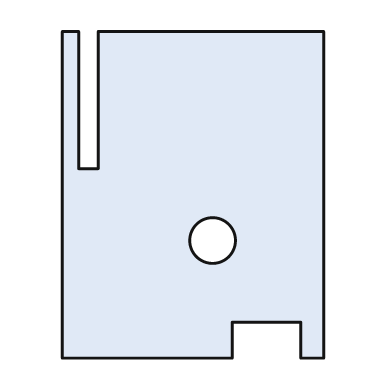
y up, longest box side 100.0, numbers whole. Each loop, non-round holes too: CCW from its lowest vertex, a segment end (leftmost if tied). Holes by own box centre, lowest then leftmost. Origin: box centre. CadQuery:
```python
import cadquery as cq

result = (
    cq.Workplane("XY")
    .moveTo(-40.0, -50.0)
    .lineTo(12.0, -50.0)
    .lineTo(12.0, -39.0)
    .lineTo(33.0, -39.0)
    .lineTo(33.0, -50.0)
    .lineTo(40.0, -50.0)
    .lineTo(40.0, 50.0)
    .lineTo(-29.0, 50.0)
    .lineTo(-29.0, 8.0)
    .lineTo(-35.0, 8.0)
    .lineTo(-35.0, 50.0)
    .lineTo(-40.0, 50.0)
    .close()
    .moveTo(6.0, -14.0)
    .circle(7.0)
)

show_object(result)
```